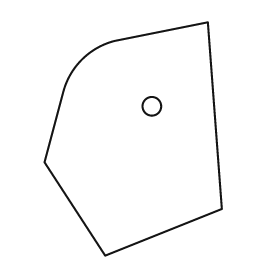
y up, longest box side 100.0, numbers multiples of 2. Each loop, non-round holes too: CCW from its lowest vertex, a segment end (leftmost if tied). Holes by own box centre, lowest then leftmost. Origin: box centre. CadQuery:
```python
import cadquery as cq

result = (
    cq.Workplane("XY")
    .moveTo(-12.0, -50.0)
    .lineTo(38.0, -30.0)
    .lineTo(32.0, 50.0)
    .lineTo(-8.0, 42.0)
    .threePointArc((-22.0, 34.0), (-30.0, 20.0))
    .lineTo(-38.0, -10.0)
    .close()
    .moveTo(8.0, 14.0)
    .circle(4.0)
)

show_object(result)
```